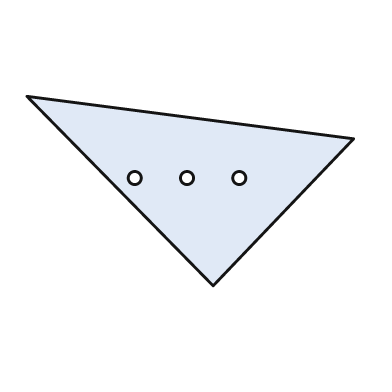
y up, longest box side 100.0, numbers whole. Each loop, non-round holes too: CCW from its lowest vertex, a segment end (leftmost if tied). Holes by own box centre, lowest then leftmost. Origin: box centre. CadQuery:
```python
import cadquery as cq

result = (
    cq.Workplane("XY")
    .moveTo(7.0, -29.0)
    .lineTo(50.0, 16.0)
    .lineTo(-50.0, 29.0)
    .close()
    .moveTo(-17.0, 4.0)
    .circle(2.0)
    .moveTo(-1.0, 4.0)
    .circle(2.0)
    .moveTo(15.0, 4.0)
    .circle(2.0)
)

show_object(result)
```